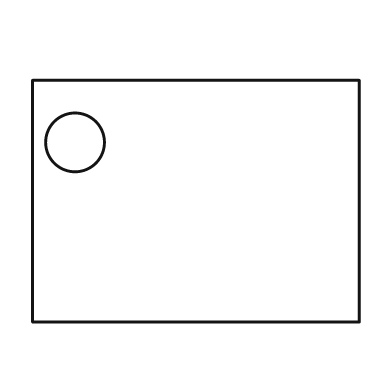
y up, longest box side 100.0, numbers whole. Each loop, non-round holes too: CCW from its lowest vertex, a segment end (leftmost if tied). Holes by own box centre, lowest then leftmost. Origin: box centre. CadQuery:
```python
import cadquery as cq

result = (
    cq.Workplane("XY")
    .moveTo(-50.0, -37.0)
    .lineTo(50.0, -37.0)
    .lineTo(50.0, 37.0)
    .lineTo(-50.0, 37.0)
    .close()
    .moveTo(-37.0, 18.0)
    .circle(9.0)
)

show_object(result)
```